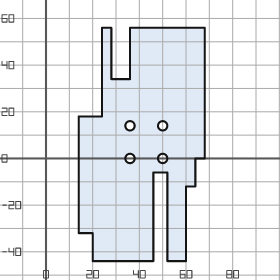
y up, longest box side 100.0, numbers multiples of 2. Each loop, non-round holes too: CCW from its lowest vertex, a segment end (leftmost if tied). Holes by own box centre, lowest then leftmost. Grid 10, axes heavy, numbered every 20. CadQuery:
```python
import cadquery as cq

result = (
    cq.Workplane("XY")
    .moveTo(20.0, -44.0)
    .lineTo(46.0, -44.0)
    .lineTo(46.0, -6.0)
    .lineTo(52.0, -6.0)
    .lineTo(52.0, -44.0)
    .lineTo(60.0, -44.0)
    .lineTo(60.0, -12.0)
    .lineTo(64.0, -12.0)
    .lineTo(64.0, 0.0)
    .lineTo(68.0, 0.0)
    .lineTo(68.0, 56.0)
    .lineTo(36.0, 56.0)
    .lineTo(36.0, 34.0)
    .lineTo(28.0, 34.0)
    .lineTo(28.0, 56.0)
    .lineTo(24.0, 56.0)
    .lineTo(24.0, 18.0)
    .lineTo(14.0, 18.0)
    .lineTo(14.0, -32.0)
    .lineTo(20.0, -32.0)
    .close()
    .moveTo(36.0, 0.0)
    .circle(2.0)
    .moveTo(50.0, 0.0)
    .circle(2.0)
    .moveTo(36.0, 14.0)
    .circle(2.0)
    .moveTo(50.0, 14.0)
    .circle(2.0)
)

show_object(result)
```